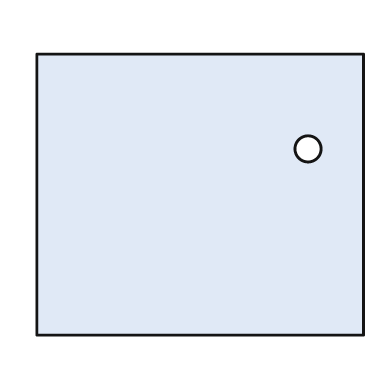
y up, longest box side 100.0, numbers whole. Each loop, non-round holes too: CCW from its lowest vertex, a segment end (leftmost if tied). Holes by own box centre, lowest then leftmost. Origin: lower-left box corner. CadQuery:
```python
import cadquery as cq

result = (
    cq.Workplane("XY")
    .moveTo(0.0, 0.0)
    .lineTo(100.0, 0.0)
    .lineTo(100.0, 86.0)
    .lineTo(0.0, 86.0)
    .close()
    .moveTo(83.0, 57.0)
    .circle(4.0)
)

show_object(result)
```